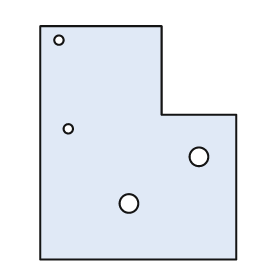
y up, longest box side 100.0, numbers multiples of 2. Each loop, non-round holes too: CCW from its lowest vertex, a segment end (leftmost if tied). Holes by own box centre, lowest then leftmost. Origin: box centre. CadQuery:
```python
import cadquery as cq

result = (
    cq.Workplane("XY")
    .moveTo(-42.0, -50.0)
    .lineTo(42.0, -50.0)
    .lineTo(42.0, 12.0)
    .lineTo(10.0, 12.0)
    .lineTo(10.0, 50.0)
    .lineTo(-42.0, 50.0)
    .close()
    .moveTo(-4.0, -26.0)
    .circle(4.0)
    .moveTo(26.0, -6.0)
    .circle(4.0)
    .moveTo(-30.0, 6.0)
    .circle(2.0)
    .moveTo(-34.0, 44.0)
    .circle(2.0)
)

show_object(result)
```